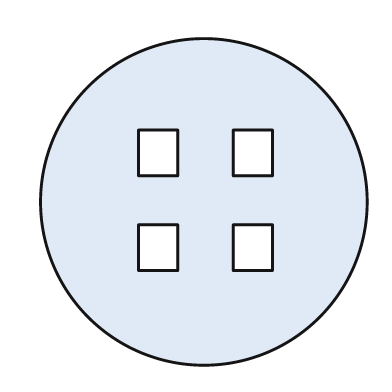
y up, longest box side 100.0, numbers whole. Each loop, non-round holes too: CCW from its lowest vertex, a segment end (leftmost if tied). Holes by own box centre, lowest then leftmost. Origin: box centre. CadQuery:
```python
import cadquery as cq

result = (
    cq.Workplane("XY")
    .moveTo(0.0, 0.0)
    .circle(50.0)
    .moveTo(-20.0, -21.0)
    .lineTo(-8.0, -21.0)
    .lineTo(-8.0, -7.0)
    .lineTo(-20.0, -7.0)
    .close()
    .moveTo(9.0, -21.0)
    .lineTo(21.0, -21.0)
    .lineTo(21.0, -7.0)
    .lineTo(9.0, -7.0)
    .close()
    .moveTo(-20.0, 8.0)
    .lineTo(-8.0, 8.0)
    .lineTo(-8.0, 22.0)
    .lineTo(-20.0, 22.0)
    .close()
    .moveTo(9.0, 8.0)
    .lineTo(21.0, 8.0)
    .lineTo(21.0, 22.0)
    .lineTo(9.0, 22.0)
    .close()
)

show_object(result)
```